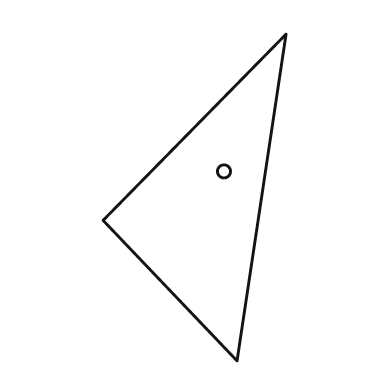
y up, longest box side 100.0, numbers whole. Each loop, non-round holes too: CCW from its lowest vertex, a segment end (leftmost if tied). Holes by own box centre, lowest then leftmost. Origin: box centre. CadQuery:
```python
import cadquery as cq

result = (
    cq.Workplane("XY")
    .moveTo(13.0, -50.0)
    .lineTo(28.0, 50.0)
    .lineTo(-28.0, -7.0)
    .close()
    .moveTo(9.0, 8.0)
    .circle(2.0)
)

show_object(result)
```